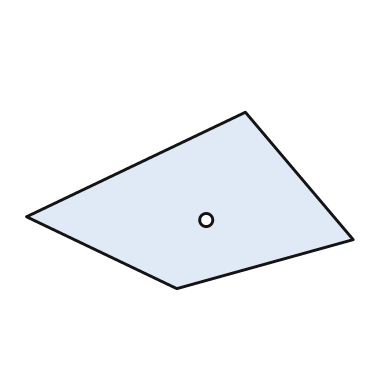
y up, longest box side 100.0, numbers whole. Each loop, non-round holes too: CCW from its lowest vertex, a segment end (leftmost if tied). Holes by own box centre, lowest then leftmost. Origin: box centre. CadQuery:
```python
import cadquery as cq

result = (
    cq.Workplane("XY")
    .moveTo(-4.0, -27.0)
    .lineTo(50.0, -12.0)
    .lineTo(17.0, 27.0)
    .lineTo(-50.0, -5.0)
    .close()
    .moveTo(5.0, -6.0)
    .circle(2.0)
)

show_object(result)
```